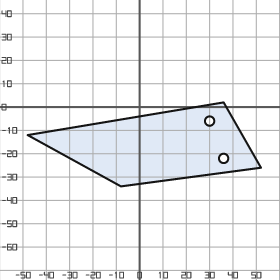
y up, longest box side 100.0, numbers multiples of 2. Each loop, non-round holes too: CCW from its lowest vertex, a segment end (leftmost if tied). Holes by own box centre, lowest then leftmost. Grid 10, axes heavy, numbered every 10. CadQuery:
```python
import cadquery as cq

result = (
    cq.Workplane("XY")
    .moveTo(-8.0, -34.0)
    .lineTo(52.0, -26.0)
    .lineTo(36.0, 2.0)
    .lineTo(-48.0, -12.0)
    .close()
    .moveTo(36.0, -22.0)
    .circle(2.0)
    .moveTo(30.0, -6.0)
    .circle(2.0)
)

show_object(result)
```